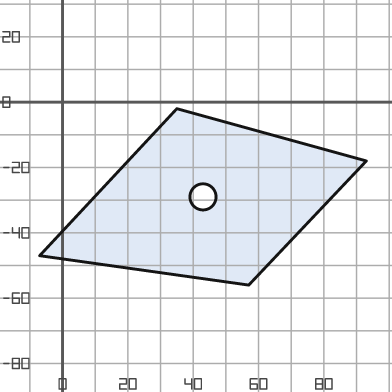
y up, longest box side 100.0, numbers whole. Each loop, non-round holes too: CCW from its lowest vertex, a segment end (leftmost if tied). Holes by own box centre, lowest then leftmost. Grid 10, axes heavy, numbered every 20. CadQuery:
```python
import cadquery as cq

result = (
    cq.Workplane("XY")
    .moveTo(57.0, -56.0)
    .lineTo(93.0, -18.0)
    .lineTo(35.0, -2.0)
    .lineTo(-7.0, -47.0)
    .close()
    .moveTo(43.0, -29.0)
    .circle(4.0)
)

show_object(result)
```